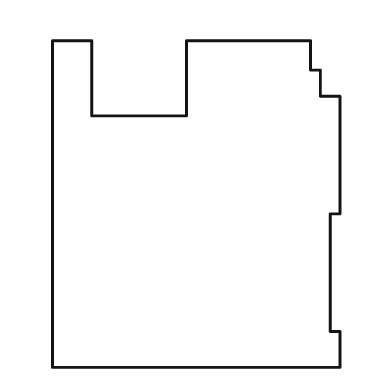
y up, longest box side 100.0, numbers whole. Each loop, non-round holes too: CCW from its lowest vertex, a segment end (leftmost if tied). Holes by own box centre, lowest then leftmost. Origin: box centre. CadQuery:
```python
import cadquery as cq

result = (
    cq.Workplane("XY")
    .moveTo(-44.0, -50.0)
    .lineTo(44.0, -50.0)
    .lineTo(44.0, -39.0)
    .lineTo(41.0, -39.0)
    .lineTo(41.0, -3.0)
    .lineTo(44.0, -3.0)
    .lineTo(44.0, 33.0)
    .lineTo(38.0, 33.0)
    .lineTo(38.0, 41.0)
    .lineTo(35.0, 41.0)
    .lineTo(35.0, 50.0)
    .lineTo(-3.0, 50.0)
    .lineTo(-3.0, 27.0)
    .lineTo(-32.0, 27.0)
    .lineTo(-32.0, 50.0)
    .lineTo(-44.0, 50.0)
    .close()
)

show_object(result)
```